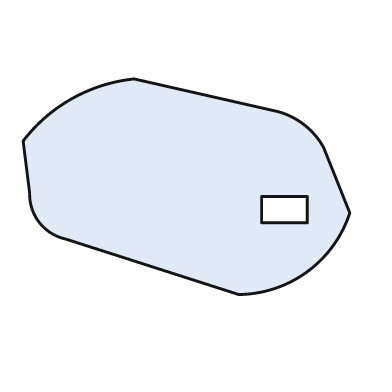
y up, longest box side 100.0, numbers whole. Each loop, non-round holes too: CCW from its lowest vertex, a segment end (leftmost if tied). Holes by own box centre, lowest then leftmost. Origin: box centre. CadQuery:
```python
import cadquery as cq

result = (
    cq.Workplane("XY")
    .moveTo(16.0, -33.0)
    .threePointArc((37.0, -26.0), (50.0, -8.0))
    .lineTo(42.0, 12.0)
    .threePointArc((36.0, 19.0), (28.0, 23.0))
    .lineTo(-16.0, 33.0)
    .threePointArc((-35.0, 27.0), (-50.0, 14.0))
    .lineTo(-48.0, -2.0)
    .threePointArc((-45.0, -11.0), (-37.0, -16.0))
    .close()
    .moveTo(23.0, -11.0)
    .lineTo(37.0, -11.0)
    .lineTo(37.0, -3.0)
    .lineTo(23.0, -3.0)
    .close()
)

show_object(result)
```